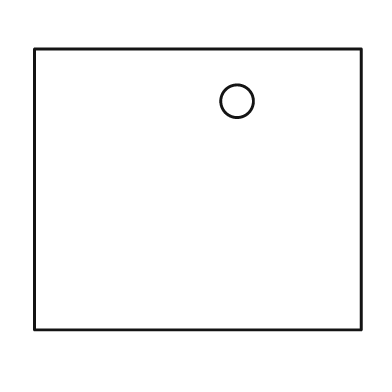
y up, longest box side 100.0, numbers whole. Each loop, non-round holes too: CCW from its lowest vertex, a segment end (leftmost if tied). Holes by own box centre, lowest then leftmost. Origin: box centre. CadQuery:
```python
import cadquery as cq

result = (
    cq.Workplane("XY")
    .moveTo(-50.0, -43.0)
    .lineTo(50.0, -43.0)
    .lineTo(50.0, 43.0)
    .lineTo(-50.0, 43.0)
    .close()
    .moveTo(12.0, 27.0)
    .circle(5.0)
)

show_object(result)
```